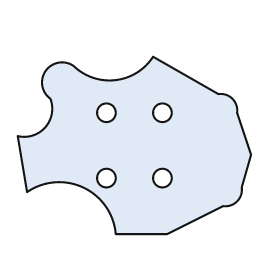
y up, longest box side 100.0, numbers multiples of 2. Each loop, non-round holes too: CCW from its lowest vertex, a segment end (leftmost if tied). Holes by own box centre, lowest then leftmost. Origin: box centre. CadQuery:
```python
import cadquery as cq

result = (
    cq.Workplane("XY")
    .moveTo(-8.0, -38.0)
    .lineTo(14.0, -38.0)
    .lineTo(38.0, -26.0)
    .threePointArc((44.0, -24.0), (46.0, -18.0))
    .lineTo(50.0, -4.0)
    .lineTo(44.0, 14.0)
    .threePointArc((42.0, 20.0), (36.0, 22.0))
    .lineTo(8.0, 38.0)
    .threePointArc((-8.0, 28.0), (-26.0, 34.0))
    .threePointArc((-38.0, 32.0), (-36.0, 20.0))
    .threePointArc((-38.0, 8.0), (-50.0, 4.0))
    .lineTo(-46.0, -20.0)
    .threePointArc((-22.0, -18.0), (-8.0, -38.0))
    .close()
    .moveTo(-12.0, -14.0)
    .circle(4.0)
    .moveTo(12.0, -14.0)
    .circle(4.0)
    .moveTo(-12.0, 14.0)
    .circle(4.0)
    .moveTo(12.0, 14.0)
    .circle(4.0)
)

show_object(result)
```